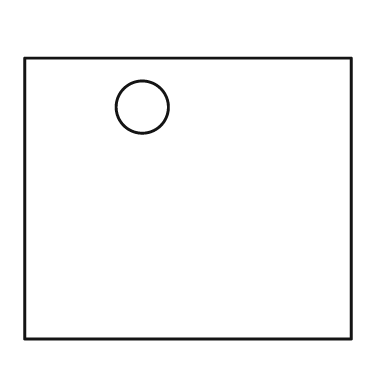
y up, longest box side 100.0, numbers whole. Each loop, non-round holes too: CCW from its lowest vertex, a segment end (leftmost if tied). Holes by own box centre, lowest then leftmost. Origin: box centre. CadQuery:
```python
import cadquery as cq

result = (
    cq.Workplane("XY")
    .moveTo(-50.0, -43.0)
    .lineTo(50.0, -43.0)
    .lineTo(50.0, 43.0)
    .lineTo(-50.0, 43.0)
    .close()
    .moveTo(-14.0, 28.0)
    .circle(8.0)
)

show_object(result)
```